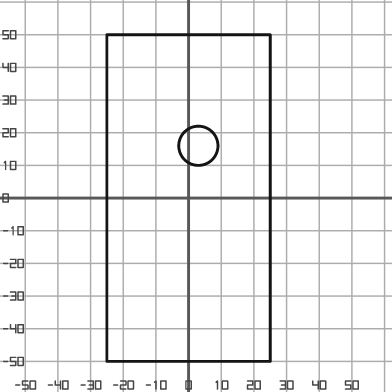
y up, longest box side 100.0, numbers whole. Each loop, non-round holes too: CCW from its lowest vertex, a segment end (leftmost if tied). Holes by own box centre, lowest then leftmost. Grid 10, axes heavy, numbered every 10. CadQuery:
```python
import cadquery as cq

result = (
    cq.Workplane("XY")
    .moveTo(-25.0, -50.0)
    .lineTo(25.0, -50.0)
    .lineTo(25.0, 50.0)
    .lineTo(-25.0, 50.0)
    .close()
    .moveTo(3.0, 16.0)
    .circle(6.0)
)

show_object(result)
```